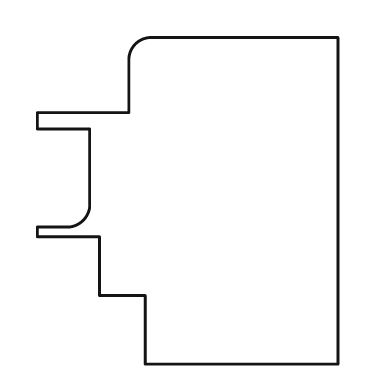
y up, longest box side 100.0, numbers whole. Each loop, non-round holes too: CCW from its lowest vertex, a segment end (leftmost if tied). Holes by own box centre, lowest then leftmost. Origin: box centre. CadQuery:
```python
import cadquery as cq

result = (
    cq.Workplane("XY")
    .moveTo(-13.0, -50.0)
    .lineTo(46.0, -50.0)
    .lineTo(46.0, 50.0)
    .lineTo(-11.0, 50.0)
    .threePointArc((-16.0, 48.0), (-18.0, 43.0))
    .lineTo(-18.0, 27.0)
    .lineTo(-46.0, 27.0)
    .lineTo(-46.0, 22.0)
    .lineTo(-30.0, 22.0)
    .lineTo(-30.0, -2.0)
    .threePointArc((-32.0, -6.0), (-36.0, -8.0))
    .lineTo(-46.0, -8.0)
    .lineTo(-46.0, -11.0)
    .lineTo(-27.0, -11.0)
    .lineTo(-27.0, -29.0)
    .lineTo(-13.0, -29.0)
    .close()
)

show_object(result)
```